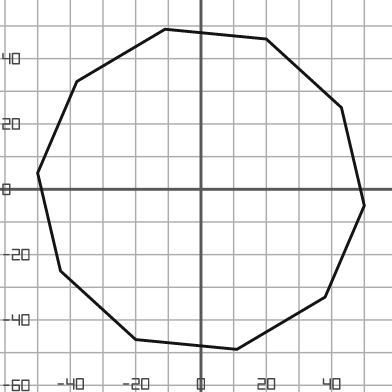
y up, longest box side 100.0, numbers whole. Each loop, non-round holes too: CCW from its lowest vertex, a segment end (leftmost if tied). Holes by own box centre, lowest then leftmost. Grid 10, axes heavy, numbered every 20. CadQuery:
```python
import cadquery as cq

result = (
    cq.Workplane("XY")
    .moveTo(11.0, -49.0)
    .lineTo(38.0, -33.0)
    .lineTo(50.0, -5.0)
    .lineTo(43.0, 25.0)
    .lineTo(20.0, 46.0)
    .lineTo(-11.0, 49.0)
    .lineTo(-38.0, 33.0)
    .lineTo(-50.0, 5.0)
    .lineTo(-43.0, -25.0)
    .lineTo(-20.0, -46.0)
    .close()
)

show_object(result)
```